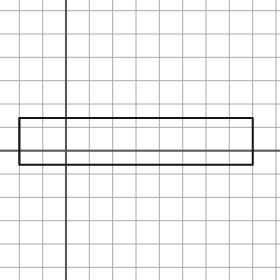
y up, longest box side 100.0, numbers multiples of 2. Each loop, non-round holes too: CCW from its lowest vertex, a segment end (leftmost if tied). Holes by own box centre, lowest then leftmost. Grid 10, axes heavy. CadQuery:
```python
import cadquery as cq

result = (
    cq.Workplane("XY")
    .moveTo(-20.0, -6.0)
    .lineTo(80.0, -6.0)
    .lineTo(80.0, 14.0)
    .lineTo(-20.0, 14.0)
    .close()
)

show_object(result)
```